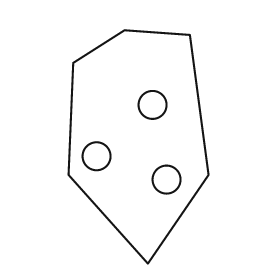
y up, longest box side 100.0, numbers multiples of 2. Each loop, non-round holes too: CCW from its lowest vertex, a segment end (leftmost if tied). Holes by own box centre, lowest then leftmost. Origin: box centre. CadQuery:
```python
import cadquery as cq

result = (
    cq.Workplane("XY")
    .moveTo(4.0, -50.0)
    .lineTo(30.0, -12.0)
    .lineTo(22.0, 48.0)
    .lineTo(-6.0, 50.0)
    .lineTo(-28.0, 36.0)
    .lineTo(-30.0, -12.0)
    .close()
    .moveTo(12.0, -14.0)
    .circle(6.0)
    .moveTo(-18.0, -4.0)
    .circle(6.0)
    .moveTo(6.0, 18.0)
    .circle(6.0)
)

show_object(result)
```